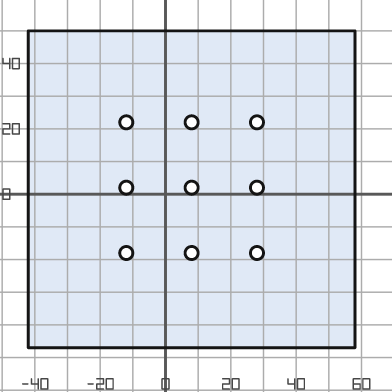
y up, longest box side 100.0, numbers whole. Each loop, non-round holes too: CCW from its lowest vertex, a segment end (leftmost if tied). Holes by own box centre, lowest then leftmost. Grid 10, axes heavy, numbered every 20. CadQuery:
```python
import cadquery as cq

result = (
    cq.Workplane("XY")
    .moveTo(-42.0, -47.0)
    .lineTo(58.0, -47.0)
    .lineTo(58.0, 50.0)
    .lineTo(-42.0, 50.0)
    .close()
    .moveTo(-12.0, -18.0)
    .circle(2.0)
    .moveTo(8.0, -18.0)
    .circle(2.0)
    .moveTo(28.0, -18.0)
    .circle(2.0)
    .moveTo(-12.0, 2.0)
    .circle(2.0)
    .moveTo(8.0, 2.0)
    .circle(2.0)
    .moveTo(28.0, 2.0)
    .circle(2.0)
    .moveTo(-12.0, 22.0)
    .circle(2.0)
    .moveTo(8.0, 22.0)
    .circle(2.0)
    .moveTo(28.0, 22.0)
    .circle(2.0)
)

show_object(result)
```